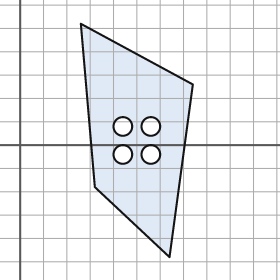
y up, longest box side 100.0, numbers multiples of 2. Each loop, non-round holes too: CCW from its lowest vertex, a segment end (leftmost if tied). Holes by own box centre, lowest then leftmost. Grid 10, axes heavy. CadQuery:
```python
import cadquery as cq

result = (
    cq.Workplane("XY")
    .moveTo(64.0, -48.0)
    .lineTo(74.0, 26.0)
    .lineTo(26.0, 52.0)
    .lineTo(32.0, -18.0)
    .close()
    .moveTo(44.0, -4.0)
    .circle(4.0)
    .moveTo(56.0, -4.0)
    .circle(4.0)
    .moveTo(44.0, 8.0)
    .circle(4.0)
    .moveTo(56.0, 8.0)
    .circle(4.0)
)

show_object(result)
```